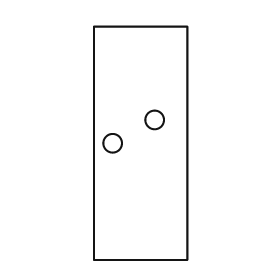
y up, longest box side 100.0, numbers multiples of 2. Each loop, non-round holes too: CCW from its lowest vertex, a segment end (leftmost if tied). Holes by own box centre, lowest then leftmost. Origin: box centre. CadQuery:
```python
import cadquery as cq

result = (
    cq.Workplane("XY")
    .moveTo(-20.0, -50.0)
    .lineTo(20.0, -50.0)
    .lineTo(20.0, 50.0)
    .lineTo(-20.0, 50.0)
    .close()
    .moveTo(-12.0, 0.0)
    .circle(4.0)
    .moveTo(6.0, 10.0)
    .circle(4.0)
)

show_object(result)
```